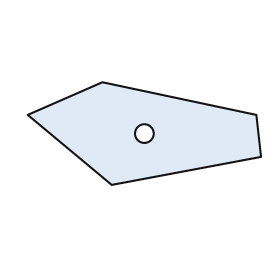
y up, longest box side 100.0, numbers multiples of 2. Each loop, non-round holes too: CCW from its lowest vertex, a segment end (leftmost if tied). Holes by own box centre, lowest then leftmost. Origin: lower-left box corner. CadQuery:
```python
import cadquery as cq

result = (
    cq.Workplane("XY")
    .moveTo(36.0, 0.0)
    .lineTo(100.0, 12.0)
    .lineTo(98.0, 30.0)
    .lineTo(32.0, 44.0)
    .lineTo(0.0, 30.0)
    .close()
    .moveTo(50.0, 22.0)
    .circle(4.0)
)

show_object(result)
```